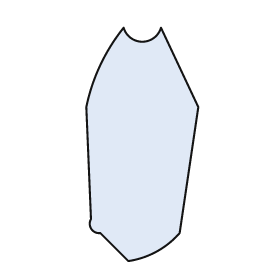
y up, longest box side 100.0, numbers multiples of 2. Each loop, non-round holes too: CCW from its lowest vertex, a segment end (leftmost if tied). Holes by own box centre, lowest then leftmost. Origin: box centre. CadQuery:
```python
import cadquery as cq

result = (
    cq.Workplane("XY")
    .moveTo(-6.0, -50.0)
    .threePointArc((6.0, -46.0), (16.0, -38.0))
    .lineTo(24.0, 16.0)
    .lineTo(8.0, 50.0)
    .threePointArc((0.0, 44.0), (-8.0, 50.0))
    .threePointArc((-18.0, 34.0), (-24.0, 16.0))
    .lineTo(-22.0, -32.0)
    .threePointArc((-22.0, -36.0), (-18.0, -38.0))
    .close()
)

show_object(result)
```